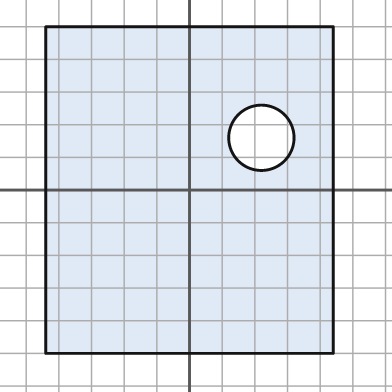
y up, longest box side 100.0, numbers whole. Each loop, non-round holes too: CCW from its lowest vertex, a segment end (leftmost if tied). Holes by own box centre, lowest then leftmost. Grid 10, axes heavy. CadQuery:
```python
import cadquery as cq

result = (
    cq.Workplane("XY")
    .moveTo(-44.0, -50.0)
    .lineTo(44.0, -50.0)
    .lineTo(44.0, 50.0)
    .lineTo(-44.0, 50.0)
    .close()
    .moveTo(22.0, 16.0)
    .circle(10.0)
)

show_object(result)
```